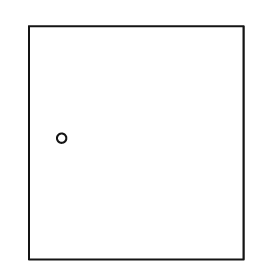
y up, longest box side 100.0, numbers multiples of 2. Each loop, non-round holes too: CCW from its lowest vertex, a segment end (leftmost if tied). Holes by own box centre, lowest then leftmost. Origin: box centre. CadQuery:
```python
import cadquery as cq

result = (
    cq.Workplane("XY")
    .moveTo(-46.0, -50.0)
    .lineTo(46.0, -50.0)
    .lineTo(46.0, 50.0)
    .lineTo(-46.0, 50.0)
    .close()
    .moveTo(-32.0, 2.0)
    .circle(2.0)
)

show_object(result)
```